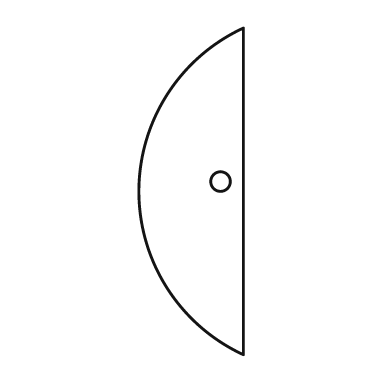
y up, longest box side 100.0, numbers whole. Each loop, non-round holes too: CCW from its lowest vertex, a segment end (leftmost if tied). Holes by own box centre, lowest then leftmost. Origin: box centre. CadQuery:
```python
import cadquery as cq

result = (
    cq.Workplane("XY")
    .moveTo(16.0, -50.0)
    .lineTo(16.0, 50.0)
    .threePointArc((-16.0, 0.0), (16.0, -50.0))
    .close()
    .moveTo(9.0, 3.0)
    .circle(3.0)
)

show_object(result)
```